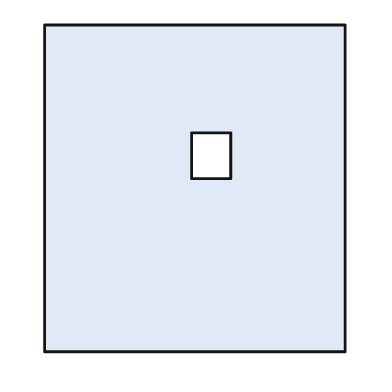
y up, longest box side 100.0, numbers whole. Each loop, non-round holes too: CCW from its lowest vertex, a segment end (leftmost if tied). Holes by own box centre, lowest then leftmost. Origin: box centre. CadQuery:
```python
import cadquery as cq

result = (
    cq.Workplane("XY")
    .moveTo(-46.0, -50.0)
    .lineTo(46.0, -50.0)
    .lineTo(46.0, 50.0)
    .lineTo(-46.0, 50.0)
    .close()
    .moveTo(-1.0, 3.0)
    .lineTo(11.0, 3.0)
    .lineTo(11.0, 17.0)
    .lineTo(-1.0, 17.0)
    .close()
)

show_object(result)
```